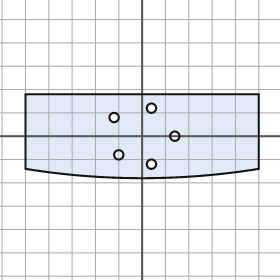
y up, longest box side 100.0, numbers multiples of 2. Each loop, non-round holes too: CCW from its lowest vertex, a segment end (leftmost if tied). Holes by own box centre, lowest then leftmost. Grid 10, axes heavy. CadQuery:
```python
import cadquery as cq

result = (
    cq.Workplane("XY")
    .moveTo(-50.0, -14.0)
    .threePointArc((0.0, -18.0), (50.0, -14.0))
    .lineTo(50.0, 18.0)
    .lineTo(-50.0, 18.0)
    .close()
    .moveTo(4.0, -12.0)
    .circle(2.0)
    .moveTo(-10.0, -8.0)
    .circle(2.0)
    .moveTo(14.0, 0.0)
    .circle(2.0)
    .moveTo(-12.0, 8.0)
    .circle(2.0)
    .moveTo(4.0, 12.0)
    .circle(2.0)
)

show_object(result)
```